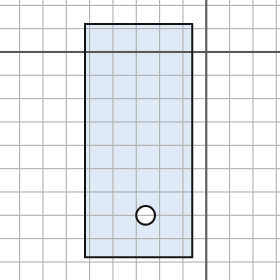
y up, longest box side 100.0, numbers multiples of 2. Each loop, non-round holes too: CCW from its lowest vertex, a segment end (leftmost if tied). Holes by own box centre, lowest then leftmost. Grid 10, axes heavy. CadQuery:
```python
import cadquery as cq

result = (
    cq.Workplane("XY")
    .moveTo(-52.0, -88.0)
    .lineTo(-6.0, -88.0)
    .lineTo(-6.0, 12.0)
    .lineTo(-52.0, 12.0)
    .close()
    .moveTo(-26.0, -70.0)
    .circle(4.0)
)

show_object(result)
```